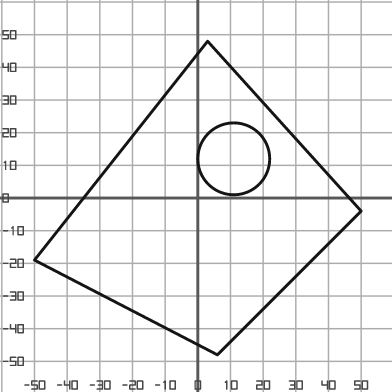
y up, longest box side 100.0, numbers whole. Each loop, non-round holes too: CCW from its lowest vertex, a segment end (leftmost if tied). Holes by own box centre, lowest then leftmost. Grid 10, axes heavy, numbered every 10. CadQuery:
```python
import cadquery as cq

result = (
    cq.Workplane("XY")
    .moveTo(6.0, -48.0)
    .lineTo(50.0, -4.0)
    .lineTo(3.0, 48.0)
    .lineTo(-50.0, -19.0)
    .close()
    .moveTo(11.0, 12.0)
    .circle(11.0)
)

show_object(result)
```